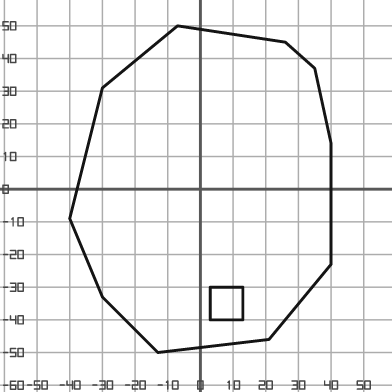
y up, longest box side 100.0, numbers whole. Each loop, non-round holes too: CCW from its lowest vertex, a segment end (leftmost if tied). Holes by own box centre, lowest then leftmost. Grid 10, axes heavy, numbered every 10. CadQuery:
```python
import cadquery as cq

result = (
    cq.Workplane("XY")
    .moveTo(-13.0, -50.0)
    .lineTo(21.0, -46.0)
    .lineTo(40.0, -23.0)
    .lineTo(40.0, 14.0)
    .lineTo(35.0, 37.0)
    .lineTo(26.0, 45.0)
    .lineTo(-7.0, 50.0)
    .lineTo(-30.0, 31.0)
    .lineTo(-40.0, -9.0)
    .lineTo(-30.0, -33.0)
    .close()
    .moveTo(3.0, -40.0)
    .lineTo(13.0, -40.0)
    .lineTo(13.0, -30.0)
    .lineTo(3.0, -30.0)
    .close()
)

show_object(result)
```